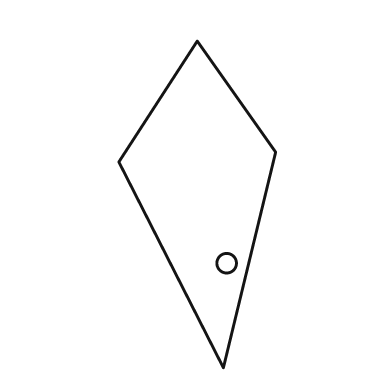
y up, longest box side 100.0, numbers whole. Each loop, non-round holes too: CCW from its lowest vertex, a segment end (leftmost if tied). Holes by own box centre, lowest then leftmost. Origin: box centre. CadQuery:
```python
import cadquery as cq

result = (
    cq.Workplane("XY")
    .moveTo(8.0, -50.0)
    .lineTo(24.0, 16.0)
    .lineTo(0.0, 50.0)
    .lineTo(-24.0, 13.0)
    .close()
    .moveTo(9.0, -18.0)
    .circle(3.0)
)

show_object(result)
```